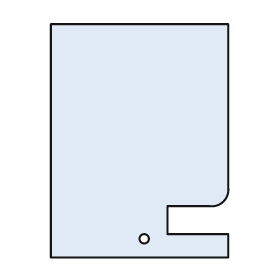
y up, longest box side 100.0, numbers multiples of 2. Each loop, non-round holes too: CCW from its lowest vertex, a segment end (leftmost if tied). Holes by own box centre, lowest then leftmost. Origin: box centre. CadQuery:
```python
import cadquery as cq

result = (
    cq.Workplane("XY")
    .moveTo(-38.0, -50.0)
    .lineTo(38.0, -50.0)
    .lineTo(38.0, -40.0)
    .lineTo(12.0, -40.0)
    .lineTo(12.0, -28.0)
    .lineTo(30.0, -28.0)
    .threePointArc((36.0, -26.0), (38.0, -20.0))
    .lineTo(38.0, 50.0)
    .lineTo(-38.0, 50.0)
    .close()
    .moveTo(2.0, -42.0)
    .circle(2.0)
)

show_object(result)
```